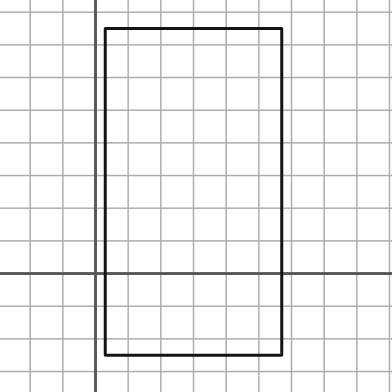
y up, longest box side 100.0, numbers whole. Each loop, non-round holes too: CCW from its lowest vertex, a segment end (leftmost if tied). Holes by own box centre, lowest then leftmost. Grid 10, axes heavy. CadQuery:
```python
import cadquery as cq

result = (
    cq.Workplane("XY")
    .moveTo(3.0, -25.0)
    .lineTo(57.0, -25.0)
    .lineTo(57.0, 75.0)
    .lineTo(3.0, 75.0)
    .close()
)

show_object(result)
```